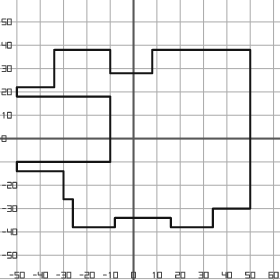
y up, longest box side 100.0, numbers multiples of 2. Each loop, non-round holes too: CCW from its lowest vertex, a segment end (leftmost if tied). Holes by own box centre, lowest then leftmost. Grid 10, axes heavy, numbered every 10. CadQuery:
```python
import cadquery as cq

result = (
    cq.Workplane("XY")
    .moveTo(-26.0, -38.0)
    .lineTo(-8.0, -38.0)
    .lineTo(-8.0, -34.0)
    .lineTo(16.0, -34.0)
    .lineTo(16.0, -38.0)
    .lineTo(34.0, -38.0)
    .lineTo(34.0, -30.0)
    .lineTo(50.0, -30.0)
    .lineTo(50.0, 38.0)
    .lineTo(8.0, 38.0)
    .lineTo(8.0, 28.0)
    .lineTo(-10.0, 28.0)
    .lineTo(-10.0, 38.0)
    .lineTo(-34.0, 38.0)
    .lineTo(-34.0, 22.0)
    .lineTo(-50.0, 22.0)
    .lineTo(-50.0, 18.0)
    .lineTo(-10.0, 18.0)
    .lineTo(-10.0, -10.0)
    .lineTo(-50.0, -10.0)
    .lineTo(-50.0, -14.0)
    .lineTo(-30.0, -14.0)
    .lineTo(-30.0, -26.0)
    .lineTo(-26.0, -26.0)
    .close()
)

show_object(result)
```